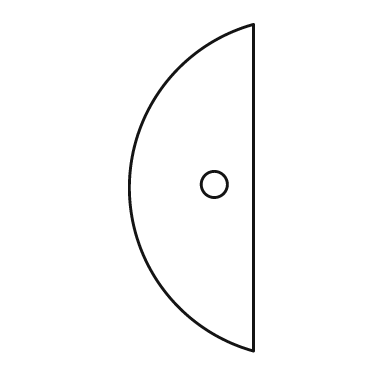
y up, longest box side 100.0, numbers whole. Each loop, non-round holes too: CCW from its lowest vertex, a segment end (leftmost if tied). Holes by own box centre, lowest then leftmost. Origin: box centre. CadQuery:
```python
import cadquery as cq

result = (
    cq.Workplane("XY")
    .moveTo(19.0, -50.0)
    .lineTo(19.0, 50.0)
    .threePointArc((-19.0, 0.0), (19.0, -50.0))
    .close()
    .moveTo(7.0, 1.0)
    .circle(4.0)
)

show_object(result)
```